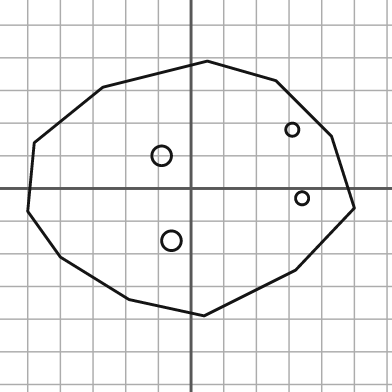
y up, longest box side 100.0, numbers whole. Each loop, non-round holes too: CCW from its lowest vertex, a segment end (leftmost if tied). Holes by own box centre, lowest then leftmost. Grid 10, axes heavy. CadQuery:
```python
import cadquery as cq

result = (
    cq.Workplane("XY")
    .moveTo(4.0, -39.0)
    .lineTo(32.0, -25.0)
    .lineTo(50.0, -6.0)
    .lineTo(43.0, 16.0)
    .lineTo(26.0, 33.0)
    .lineTo(5.0, 39.0)
    .lineTo(-27.0, 31.0)
    .lineTo(-48.0, 14.0)
    .lineTo(-50.0, -7.0)
    .lineTo(-40.0, -21.0)
    .lineTo(-19.0, -34.0)
    .close()
    .moveTo(-6.0, -16.0)
    .circle(3.0)
    .moveTo(34.0, -3.0)
    .circle(2.0)
    .moveTo(-9.0, 10.0)
    .circle(3.0)
    .moveTo(31.0, 18.0)
    .circle(2.0)
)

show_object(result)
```